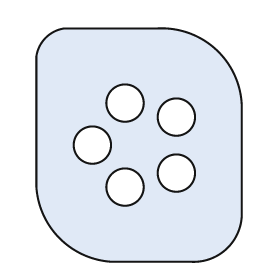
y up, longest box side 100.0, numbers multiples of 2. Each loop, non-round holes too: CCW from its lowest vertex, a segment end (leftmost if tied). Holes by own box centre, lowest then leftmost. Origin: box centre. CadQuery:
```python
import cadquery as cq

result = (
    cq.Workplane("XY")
    .moveTo(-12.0, -50.0)
    .lineTo(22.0, -50.0)
    .threePointArc((38.0, -44.0), (44.0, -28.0))
    .lineTo(44.0, 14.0)
    .threePointArc((34.0, 40.0), (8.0, 50.0))
    .lineTo(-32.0, 50.0)
    .threePointArc((-40.0, 46.0), (-44.0, 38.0))
    .lineTo(-44.0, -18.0)
    .threePointArc((-34.0, -40.0), (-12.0, -50.0))
    .close()
    .moveTo(-6.0, -18.0)
    .circle(8.0)
    .moveTo(16.0, -12.0)
    .circle(8.0)
    .moveTo(-20.0, 0.0)
    .circle(8.0)
    .moveTo(16.0, 12.0)
    .circle(8.0)
    .moveTo(-6.0, 18.0)
    .circle(8.0)
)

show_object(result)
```